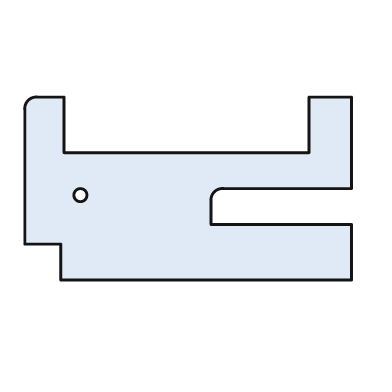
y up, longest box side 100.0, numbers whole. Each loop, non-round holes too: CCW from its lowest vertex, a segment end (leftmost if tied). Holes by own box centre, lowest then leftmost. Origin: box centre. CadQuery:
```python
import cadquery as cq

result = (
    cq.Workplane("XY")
    .moveTo(-39.0, -28.0)
    .lineTo(50.0, -28.0)
    .lineTo(50.0, -11.0)
    .lineTo(7.0, -11.0)
    .lineTo(7.0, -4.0)
    .threePointArc((8.0, -1.0), (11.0, 0.0))
    .lineTo(50.0, 0.0)
    .lineTo(50.0, 28.0)
    .lineTo(37.0, 28.0)
    .lineTo(37.0, 11.0)
    .lineTo(-38.0, 11.0)
    .lineTo(-38.0, 28.0)
    .lineTo(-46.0, 28.0)
    .threePointArc((-49.0, 27.0), (-50.0, 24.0))
    .lineTo(-50.0, -17.0)
    .lineTo(-39.0, -17.0)
    .close()
    .moveTo(-33.0, -2.0)
    .circle(2.0)
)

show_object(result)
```